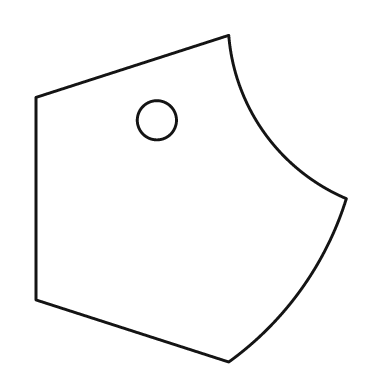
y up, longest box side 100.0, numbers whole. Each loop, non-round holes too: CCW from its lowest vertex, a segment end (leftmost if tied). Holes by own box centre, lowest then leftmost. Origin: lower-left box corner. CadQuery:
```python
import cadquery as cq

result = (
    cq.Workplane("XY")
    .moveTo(59.0, 0.0)
    .threePointArc((81.0, 22.0), (95.0, 50.0))
    .threePointArc((70.0, 70.0), (59.0, 100.0))
    .lineTo(0.0, 81.0)
    .lineTo(0.0, 19.0)
    .close()
    .moveTo(37.0, 74.0)
    .circle(6.0)
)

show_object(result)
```